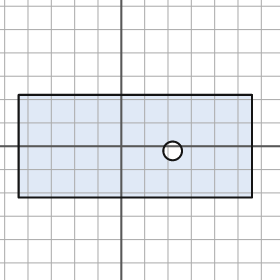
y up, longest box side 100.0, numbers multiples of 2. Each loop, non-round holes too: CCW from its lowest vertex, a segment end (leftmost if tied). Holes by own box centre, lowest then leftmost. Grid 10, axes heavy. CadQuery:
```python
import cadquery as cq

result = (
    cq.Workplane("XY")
    .moveTo(-44.0, -22.0)
    .lineTo(56.0, -22.0)
    .lineTo(56.0, 22.0)
    .lineTo(-44.0, 22.0)
    .close()
    .moveTo(22.0, -2.0)
    .circle(4.0)
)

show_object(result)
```